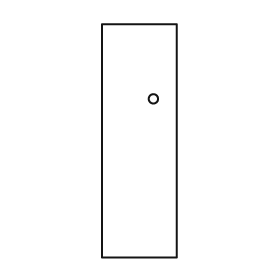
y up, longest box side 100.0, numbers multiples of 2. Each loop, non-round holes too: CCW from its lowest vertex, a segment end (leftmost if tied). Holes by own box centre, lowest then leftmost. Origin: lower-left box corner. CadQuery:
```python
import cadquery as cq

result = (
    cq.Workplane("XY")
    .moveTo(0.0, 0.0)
    .lineTo(32.0, 0.0)
    .lineTo(32.0, 100.0)
    .lineTo(0.0, 100.0)
    .close()
    .moveTo(22.0, 68.0)
    .circle(2.0)
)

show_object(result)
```